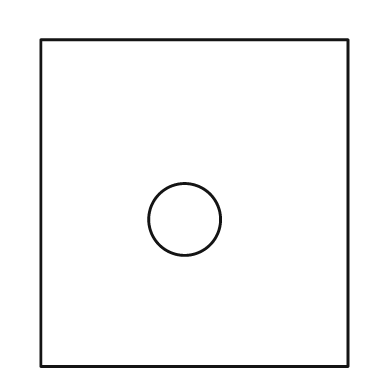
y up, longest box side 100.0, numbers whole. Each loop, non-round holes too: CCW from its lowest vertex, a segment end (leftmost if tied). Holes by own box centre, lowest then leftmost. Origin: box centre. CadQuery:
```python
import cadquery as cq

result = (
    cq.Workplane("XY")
    .moveTo(-47.0, -50.0)
    .lineTo(47.0, -50.0)
    .lineTo(47.0, 50.0)
    .lineTo(-47.0, 50.0)
    .close()
    .moveTo(-3.0, -5.0)
    .circle(11.0)
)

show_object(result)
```